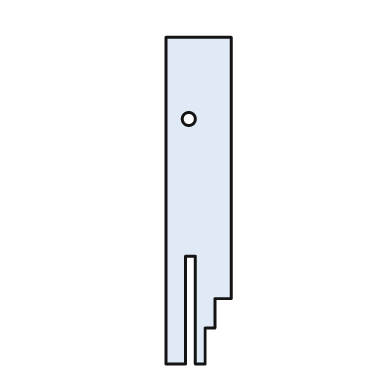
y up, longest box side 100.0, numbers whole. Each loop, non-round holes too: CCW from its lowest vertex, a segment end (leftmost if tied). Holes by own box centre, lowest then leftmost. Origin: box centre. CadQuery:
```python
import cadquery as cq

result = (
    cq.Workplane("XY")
    .moveTo(-10.0, -50.0)
    .lineTo(-4.0, -50.0)
    .lineTo(-4.0, -17.0)
    .lineTo(-1.0, -17.0)
    .lineTo(-1.0, -50.0)
    .lineTo(2.0, -50.0)
    .lineTo(2.0, -39.0)
    .lineTo(5.0, -39.0)
    .lineTo(5.0, -30.0)
    .lineTo(10.0, -30.0)
    .lineTo(10.0, 50.0)
    .lineTo(-10.0, 50.0)
    .close()
    .moveTo(-3.0, 25.0)
    .circle(2.0)
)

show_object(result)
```